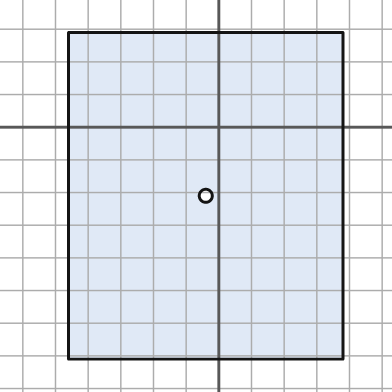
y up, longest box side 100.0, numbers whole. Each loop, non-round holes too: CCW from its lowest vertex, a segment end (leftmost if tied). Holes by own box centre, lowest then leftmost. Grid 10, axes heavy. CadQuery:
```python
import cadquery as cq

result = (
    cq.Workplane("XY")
    .moveTo(-46.0, -71.0)
    .lineTo(38.0, -71.0)
    .lineTo(38.0, 29.0)
    .lineTo(-46.0, 29.0)
    .close()
    .moveTo(-4.0, -21.0)
    .circle(2.0)
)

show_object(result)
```